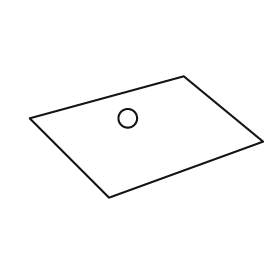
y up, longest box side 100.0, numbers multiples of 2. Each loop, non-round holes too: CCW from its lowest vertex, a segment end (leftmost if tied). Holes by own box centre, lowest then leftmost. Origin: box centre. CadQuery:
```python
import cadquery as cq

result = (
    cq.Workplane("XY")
    .moveTo(-16.0, -26.0)
    .lineTo(50.0, -2.0)
    .lineTo(16.0, 26.0)
    .lineTo(-50.0, 8.0)
    .close()
    .moveTo(-8.0, 8.0)
    .circle(4.0)
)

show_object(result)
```